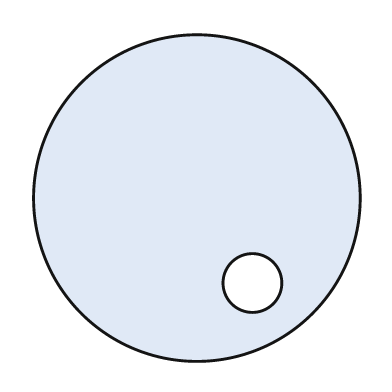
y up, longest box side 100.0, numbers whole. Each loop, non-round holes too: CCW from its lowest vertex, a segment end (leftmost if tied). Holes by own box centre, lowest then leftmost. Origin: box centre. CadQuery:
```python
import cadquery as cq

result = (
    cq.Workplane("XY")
    .moveTo(0.0, 0.0)
    .circle(50.0)
    .moveTo(17.0, -26.0)
    .circle(9.0)
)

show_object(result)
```